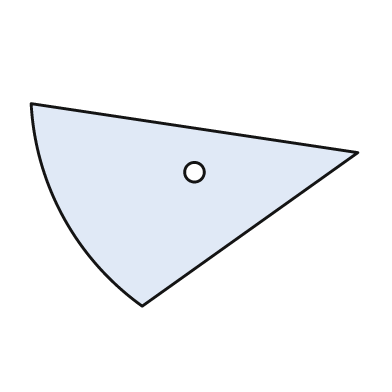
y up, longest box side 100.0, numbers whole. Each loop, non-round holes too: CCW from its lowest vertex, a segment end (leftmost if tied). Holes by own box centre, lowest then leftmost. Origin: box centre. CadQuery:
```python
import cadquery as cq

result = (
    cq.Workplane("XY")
    .moveTo(-16.0, -31.0)
    .lineTo(50.0, 16.0)
    .lineTo(-50.0, 31.0)
    .threePointArc((-40.0, -4.0), (-16.0, -31.0))
    .close()
    .moveTo(0.0, 10.0)
    .circle(3.0)
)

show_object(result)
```